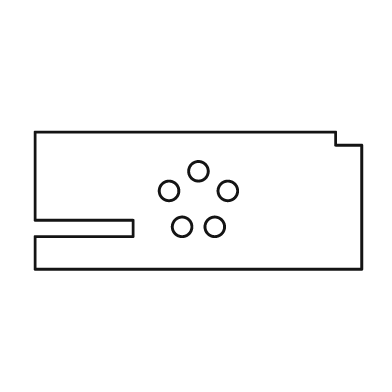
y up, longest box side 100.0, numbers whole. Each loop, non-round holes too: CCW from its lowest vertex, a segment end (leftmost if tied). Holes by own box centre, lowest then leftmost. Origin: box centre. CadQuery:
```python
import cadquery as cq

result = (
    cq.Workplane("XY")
    .moveTo(-50.0, -21.0)
    .lineTo(50.0, -21.0)
    .lineTo(50.0, 17.0)
    .lineTo(42.0, 17.0)
    .lineTo(42.0, 21.0)
    .lineTo(-50.0, 21.0)
    .lineTo(-50.0, -6.0)
    .lineTo(-20.0, -6.0)
    .lineTo(-20.0, -11.0)
    .lineTo(-50.0, -11.0)
    .close()
    .moveTo(-5.0, -8.0)
    .circle(3.0)
    .moveTo(5.0, -8.0)
    .circle(3.0)
    .moveTo(-9.0, 3.0)
    .circle(3.0)
    .moveTo(9.0, 3.0)
    .circle(3.0)
    .moveTo(0.0, 9.0)
    .circle(3.0)
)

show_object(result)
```